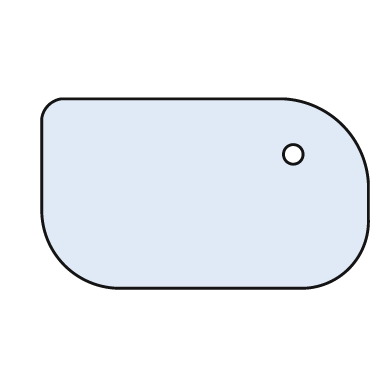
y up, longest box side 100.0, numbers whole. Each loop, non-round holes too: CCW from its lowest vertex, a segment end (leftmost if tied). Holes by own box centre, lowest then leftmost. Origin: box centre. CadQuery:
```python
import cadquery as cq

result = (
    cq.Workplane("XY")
    .moveTo(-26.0, -29.0)
    .lineTo(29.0, -29.0)
    .threePointArc((44.0, -23.0), (50.0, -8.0))
    .lineTo(50.0, 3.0)
    .threePointArc((42.0, 21.0), (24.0, 29.0))
    .lineTo(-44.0, 29.0)
    .threePointArc((-48.0, 27.0), (-50.0, 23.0))
    .lineTo(-50.0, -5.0)
    .threePointArc((-43.0, -22.0), (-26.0, -29.0))
    .close()
    .moveTo(27.0, 12.0)
    .circle(3.0)
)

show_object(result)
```